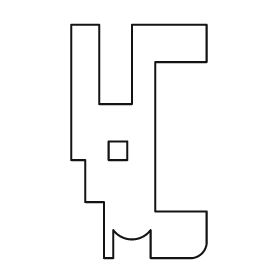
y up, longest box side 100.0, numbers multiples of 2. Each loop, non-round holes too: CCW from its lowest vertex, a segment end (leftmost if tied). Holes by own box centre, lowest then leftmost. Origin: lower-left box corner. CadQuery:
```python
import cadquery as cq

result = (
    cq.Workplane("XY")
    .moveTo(14.0, 0.0)
    .lineTo(18.0, 0.0)
    .lineTo(18.0, 12.0)
    .threePointArc((26.0, 8.0), (34.0, 12.0))
    .lineTo(34.0, 0.0)
    .lineTo(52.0, 0.0)
    .threePointArc((56.0, 2.0), (58.0, 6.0))
    .lineTo(58.0, 20.0)
    .lineTo(36.0, 20.0)
    .lineTo(36.0, 84.0)
    .lineTo(58.0, 84.0)
    .lineTo(58.0, 100.0)
    .lineTo(26.0, 100.0)
    .lineTo(26.0, 66.0)
    .lineTo(12.0, 66.0)
    .lineTo(12.0, 100.0)
    .lineTo(0.0, 100.0)
    .lineTo(0.0, 42.0)
    .lineTo(6.0, 42.0)
    .lineTo(6.0, 24.0)
    .lineTo(14.0, 24.0)
    .close()
    .moveTo(16.0, 42.0)
    .lineTo(24.0, 42.0)
    .lineTo(24.0, 50.0)
    .lineTo(16.0, 50.0)
    .close()
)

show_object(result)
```